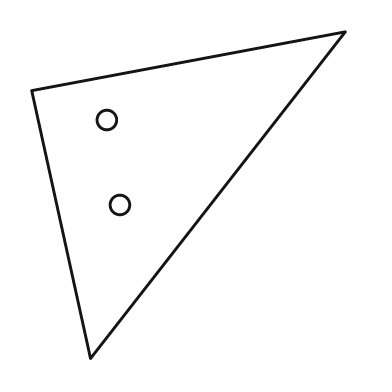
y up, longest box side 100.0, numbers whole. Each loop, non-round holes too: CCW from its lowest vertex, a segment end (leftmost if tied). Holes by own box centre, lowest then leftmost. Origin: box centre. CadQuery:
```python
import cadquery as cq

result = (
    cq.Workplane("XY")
    .moveTo(-30.0, -50.0)
    .lineTo(48.0, 50.0)
    .lineTo(-48.0, 32.0)
    .close()
    .moveTo(-21.0, -3.0)
    .circle(3.0)
    .moveTo(-25.0, 23.0)
    .circle(3.0)
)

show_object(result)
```